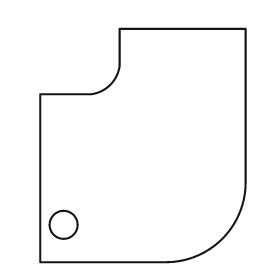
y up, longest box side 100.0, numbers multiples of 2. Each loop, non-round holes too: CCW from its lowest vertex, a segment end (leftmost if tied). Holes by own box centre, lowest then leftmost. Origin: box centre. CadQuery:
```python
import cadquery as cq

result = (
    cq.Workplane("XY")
    .moveTo(-44.0, -50.0)
    .lineTo(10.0, -50.0)
    .threePointArc((34.0, -40.0), (44.0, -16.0))
    .lineTo(44.0, 50.0)
    .lineTo(-10.0, 50.0)
    .lineTo(-10.0, 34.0)
    .threePointArc((-14.0, 26.0), (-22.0, 22.0))
    .lineTo(-44.0, 22.0)
    .close()
    .moveTo(-34.0, -34.0)
    .circle(6.0)
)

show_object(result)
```